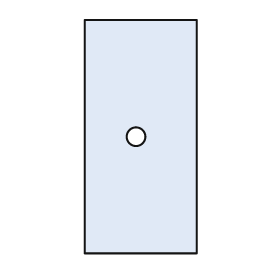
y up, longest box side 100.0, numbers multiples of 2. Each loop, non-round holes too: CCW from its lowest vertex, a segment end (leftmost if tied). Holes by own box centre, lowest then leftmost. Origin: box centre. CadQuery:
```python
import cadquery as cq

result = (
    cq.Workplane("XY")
    .moveTo(-24.0, -50.0)
    .lineTo(24.0, -50.0)
    .lineTo(24.0, 50.0)
    .lineTo(-24.0, 50.0)
    .close()
    .moveTo(-2.0, 0.0)
    .circle(4.0)
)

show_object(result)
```